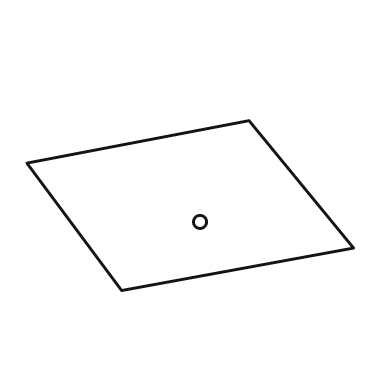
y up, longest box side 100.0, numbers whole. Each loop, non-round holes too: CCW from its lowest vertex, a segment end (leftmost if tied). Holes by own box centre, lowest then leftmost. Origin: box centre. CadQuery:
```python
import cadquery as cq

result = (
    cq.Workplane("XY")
    .moveTo(-21.0, -26.0)
    .lineTo(50.0, -13.0)
    .lineTo(18.0, 26.0)
    .lineTo(-50.0, 13.0)
    .close()
    .moveTo(3.0, -5.0)
    .circle(2.0)
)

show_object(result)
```